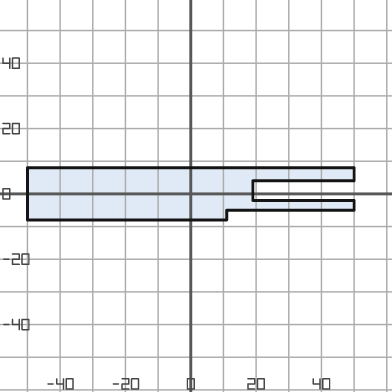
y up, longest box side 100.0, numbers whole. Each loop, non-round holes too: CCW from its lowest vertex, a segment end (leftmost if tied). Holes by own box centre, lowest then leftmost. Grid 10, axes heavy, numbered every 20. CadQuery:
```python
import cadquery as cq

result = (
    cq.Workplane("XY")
    .moveTo(-50.0, -8.0)
    .lineTo(11.0, -8.0)
    .lineTo(11.0, -5.0)
    .lineTo(50.0, -5.0)
    .lineTo(50.0, -2.0)
    .lineTo(19.0, -2.0)
    .lineTo(19.0, 4.0)
    .lineTo(50.0, 4.0)
    .lineTo(50.0, 8.0)
    .lineTo(-50.0, 8.0)
    .close()
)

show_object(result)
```